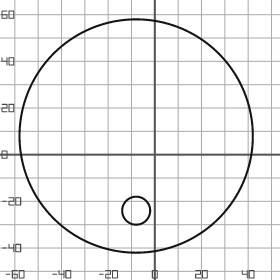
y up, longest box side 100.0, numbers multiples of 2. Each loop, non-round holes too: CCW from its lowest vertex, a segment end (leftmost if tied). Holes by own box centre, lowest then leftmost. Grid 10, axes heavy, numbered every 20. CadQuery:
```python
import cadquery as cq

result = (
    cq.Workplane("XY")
    .moveTo(-8.0, 8.0)
    .circle(50.0)
    .moveTo(-8.0, -24.0)
    .circle(6.0)
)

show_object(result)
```